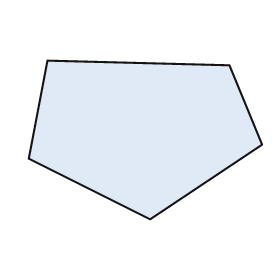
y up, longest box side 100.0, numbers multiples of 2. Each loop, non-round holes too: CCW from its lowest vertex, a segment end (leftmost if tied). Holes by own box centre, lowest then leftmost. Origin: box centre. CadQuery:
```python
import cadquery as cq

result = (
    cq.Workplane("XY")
    .moveTo(2.0, -34.0)
    .lineTo(50.0, -2.0)
    .lineTo(36.0, 32.0)
    .lineTo(-42.0, 34.0)
    .lineTo(-50.0, -8.0)
    .close()
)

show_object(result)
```